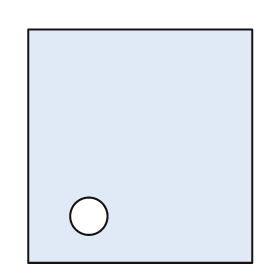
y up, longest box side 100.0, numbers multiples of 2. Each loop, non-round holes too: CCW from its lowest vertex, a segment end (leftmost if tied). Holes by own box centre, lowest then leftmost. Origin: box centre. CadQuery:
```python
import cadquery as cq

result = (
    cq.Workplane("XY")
    .moveTo(-48.0, -50.0)
    .lineTo(48.0, -50.0)
    .lineTo(48.0, 50.0)
    .lineTo(-48.0, 50.0)
    .close()
    .moveTo(-22.0, -30.0)
    .circle(8.0)
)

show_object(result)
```